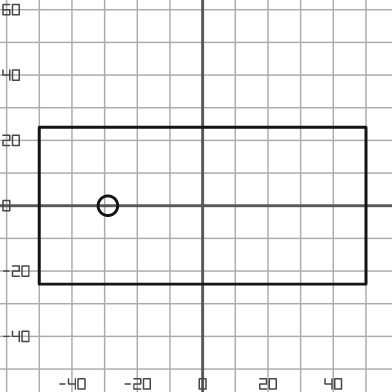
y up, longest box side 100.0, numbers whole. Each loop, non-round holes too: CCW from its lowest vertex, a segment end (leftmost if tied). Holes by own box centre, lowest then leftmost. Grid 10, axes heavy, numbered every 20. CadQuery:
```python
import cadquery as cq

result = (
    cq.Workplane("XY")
    .moveTo(-50.0, -24.0)
    .lineTo(50.0, -24.0)
    .lineTo(50.0, 24.0)
    .lineTo(-50.0, 24.0)
    .close()
    .moveTo(-29.0, 0.0)
    .circle(3.0)
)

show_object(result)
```